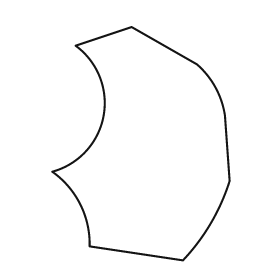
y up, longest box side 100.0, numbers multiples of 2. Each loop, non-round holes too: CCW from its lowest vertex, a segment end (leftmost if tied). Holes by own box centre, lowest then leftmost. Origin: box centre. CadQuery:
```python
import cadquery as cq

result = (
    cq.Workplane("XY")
    .moveTo(18.0, -50.0)
    .threePointArc((30.0, -34.0), (38.0, -16.0))
    .lineTo(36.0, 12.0)
    .threePointArc((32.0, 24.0), (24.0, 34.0))
    .lineTo(-4.0, 50.0)
    .lineTo(-28.0, 42.0)
    .threePointArc((-16.0, 12.0), (-38.0, -12.0))
    .threePointArc((-26.0, -26.0), (-22.0, -44.0))
    .close()
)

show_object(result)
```